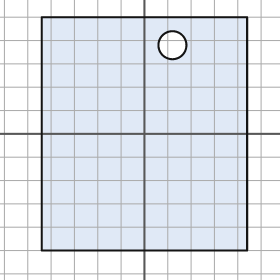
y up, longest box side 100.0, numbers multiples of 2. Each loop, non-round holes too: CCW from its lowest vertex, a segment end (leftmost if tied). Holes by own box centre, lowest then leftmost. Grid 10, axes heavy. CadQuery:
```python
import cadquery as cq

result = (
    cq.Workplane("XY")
    .moveTo(-44.0, -50.0)
    .lineTo(44.0, -50.0)
    .lineTo(44.0, 50.0)
    .lineTo(-44.0, 50.0)
    .close()
    .moveTo(12.0, 38.0)
    .circle(6.0)
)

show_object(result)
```